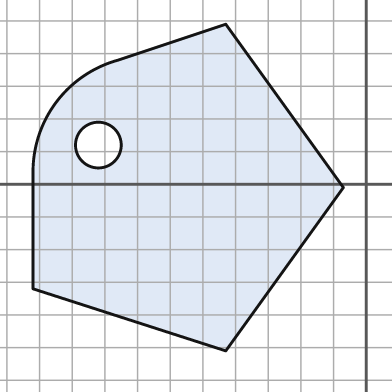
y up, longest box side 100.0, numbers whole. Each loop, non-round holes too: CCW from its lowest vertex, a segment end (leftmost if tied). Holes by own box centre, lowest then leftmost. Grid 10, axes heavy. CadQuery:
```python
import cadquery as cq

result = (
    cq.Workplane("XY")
    .moveTo(-43.0, -51.0)
    .lineTo(-7.0, -1.0)
    .lineTo(-43.0, 49.0)
    .lineTo(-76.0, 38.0)
    .threePointArc((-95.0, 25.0), (-102.0, 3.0))
    .lineTo(-102.0, -32.0)
    .close()
    .moveTo(-82.0, 12.0)
    .circle(7.0)
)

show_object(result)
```